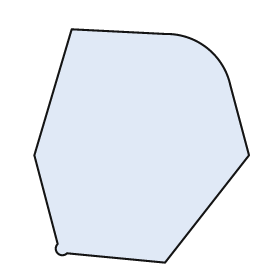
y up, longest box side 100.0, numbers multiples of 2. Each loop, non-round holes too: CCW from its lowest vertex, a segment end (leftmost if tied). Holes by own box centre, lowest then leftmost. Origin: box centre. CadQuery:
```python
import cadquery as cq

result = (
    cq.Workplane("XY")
    .moveTo(10.0, -50.0)
    .lineTo(46.0, -4.0)
    .lineTo(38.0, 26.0)
    .threePointArc((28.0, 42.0), (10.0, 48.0))
    .lineTo(-30.0, 50.0)
    .lineTo(-46.0, -4.0)
    .lineTo(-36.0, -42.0)
    .threePointArc((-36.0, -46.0), (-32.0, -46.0))
    .close()
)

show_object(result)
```